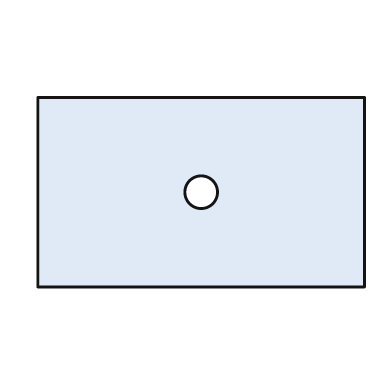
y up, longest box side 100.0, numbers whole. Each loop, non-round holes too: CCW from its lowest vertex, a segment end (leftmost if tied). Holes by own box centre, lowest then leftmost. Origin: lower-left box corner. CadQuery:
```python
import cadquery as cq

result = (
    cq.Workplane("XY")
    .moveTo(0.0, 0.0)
    .lineTo(100.0, 0.0)
    .lineTo(100.0, 58.0)
    .lineTo(0.0, 58.0)
    .close()
    .moveTo(50.0, 29.0)
    .circle(5.0)
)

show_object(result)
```